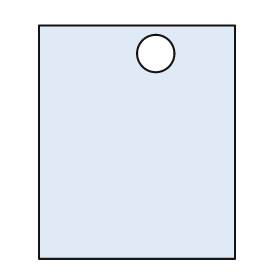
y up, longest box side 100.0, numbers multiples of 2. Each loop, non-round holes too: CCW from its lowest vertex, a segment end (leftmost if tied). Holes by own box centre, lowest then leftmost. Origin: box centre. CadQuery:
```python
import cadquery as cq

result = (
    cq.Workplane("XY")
    .moveTo(-42.0, -50.0)
    .lineTo(42.0, -50.0)
    .lineTo(42.0, 50.0)
    .lineTo(-42.0, 50.0)
    .close()
    .moveTo(8.0, 38.0)
    .circle(8.0)
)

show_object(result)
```